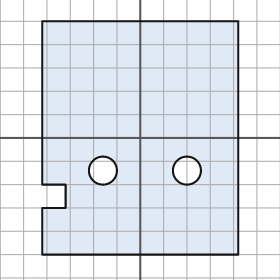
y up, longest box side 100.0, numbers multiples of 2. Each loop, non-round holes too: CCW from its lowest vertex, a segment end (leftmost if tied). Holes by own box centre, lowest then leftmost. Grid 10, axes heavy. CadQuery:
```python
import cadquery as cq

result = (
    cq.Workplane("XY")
    .moveTo(-42.0, -50.0)
    .lineTo(42.0, -50.0)
    .lineTo(42.0, 50.0)
    .lineTo(-42.0, 50.0)
    .lineTo(-42.0, -20.0)
    .lineTo(-32.0, -20.0)
    .lineTo(-32.0, -30.0)
    .lineTo(-42.0, -30.0)
    .close()
    .moveTo(-16.0, -14.0)
    .circle(6.0)
    .moveTo(20.0, -14.0)
    .circle(6.0)
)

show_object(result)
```